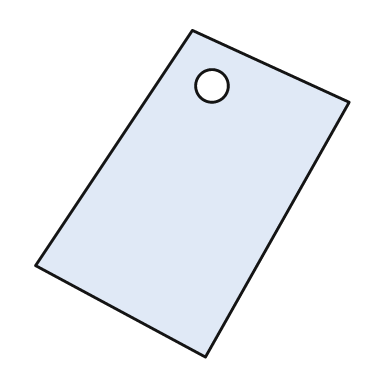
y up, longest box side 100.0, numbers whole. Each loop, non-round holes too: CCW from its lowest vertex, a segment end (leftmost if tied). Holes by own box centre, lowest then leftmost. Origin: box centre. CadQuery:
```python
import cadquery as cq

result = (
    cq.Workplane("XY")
    .moveTo(4.0, -50.0)
    .lineTo(48.0, 28.0)
    .lineTo(0.0, 50.0)
    .lineTo(-48.0, -22.0)
    .close()
    .moveTo(6.0, 33.0)
    .circle(5.0)
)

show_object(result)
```